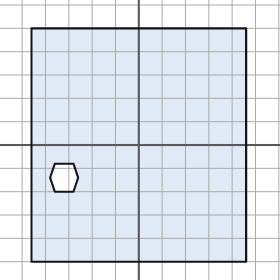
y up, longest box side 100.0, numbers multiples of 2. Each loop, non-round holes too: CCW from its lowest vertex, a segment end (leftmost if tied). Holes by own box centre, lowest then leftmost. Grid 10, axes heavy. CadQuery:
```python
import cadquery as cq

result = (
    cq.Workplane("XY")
    .moveTo(-46.0, -50.0)
    .lineTo(46.0, -50.0)
    .lineTo(46.0, 50.0)
    .lineTo(-46.0, 50.0)
    .close()
    .moveTo(-36.0, -20.0)
    .lineTo(-28.0, -20.0)
    .lineTo(-26.0, -14.0)
    .lineTo(-28.0, -8.0)
    .lineTo(-36.0, -8.0)
    .lineTo(-38.0, -14.0)
    .close()
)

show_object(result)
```